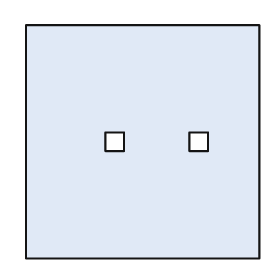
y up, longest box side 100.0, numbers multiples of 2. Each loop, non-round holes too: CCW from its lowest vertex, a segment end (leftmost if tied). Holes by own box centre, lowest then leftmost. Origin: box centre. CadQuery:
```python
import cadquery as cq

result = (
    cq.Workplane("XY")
    .moveTo(-50.0, -50.0)
    .lineTo(50.0, -50.0)
    .lineTo(50.0, 50.0)
    .lineTo(-50.0, 50.0)
    .close()
    .moveTo(-16.0, -4.0)
    .lineTo(-8.0, -4.0)
    .lineTo(-8.0, 4.0)
    .lineTo(-16.0, 4.0)
    .close()
    .moveTo(20.0, -4.0)
    .lineTo(28.0, -4.0)
    .lineTo(28.0, 4.0)
    .lineTo(20.0, 4.0)
    .close()
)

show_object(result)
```